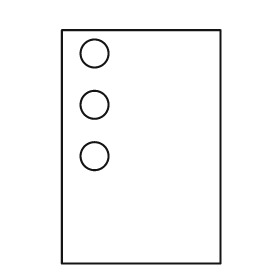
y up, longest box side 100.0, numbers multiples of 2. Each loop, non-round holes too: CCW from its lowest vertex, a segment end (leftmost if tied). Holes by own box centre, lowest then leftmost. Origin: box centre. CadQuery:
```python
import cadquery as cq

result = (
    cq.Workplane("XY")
    .moveTo(-34.0, -50.0)
    .lineTo(34.0, -50.0)
    .lineTo(34.0, 50.0)
    .lineTo(-34.0, 50.0)
    .close()
    .moveTo(-20.0, -4.0)
    .circle(6.0)
    .moveTo(-20.0, 18.0)
    .circle(6.0)
    .moveTo(-20.0, 40.0)
    .circle(6.0)
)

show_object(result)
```